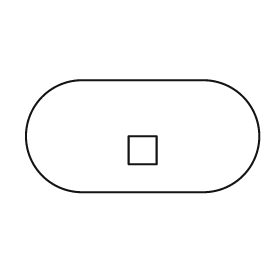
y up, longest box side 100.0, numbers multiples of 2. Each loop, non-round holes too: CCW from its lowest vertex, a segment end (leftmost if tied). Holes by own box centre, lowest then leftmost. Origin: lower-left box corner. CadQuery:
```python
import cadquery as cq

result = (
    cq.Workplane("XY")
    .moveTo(24.0, 0.0)
    .lineTo(76.0, 0.0)
    .threePointArc((100.0, 24.0), (76.0, 48.0))
    .lineTo(24.0, 48.0)
    .threePointArc((0.0, 24.0), (24.0, 0.0))
    .close()
    .moveTo(44.0, 12.0)
    .lineTo(56.0, 12.0)
    .lineTo(56.0, 24.0)
    .lineTo(44.0, 24.0)
    .close()
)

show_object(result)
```